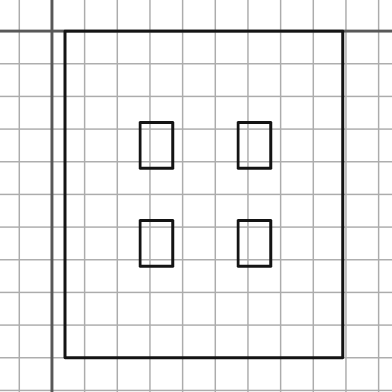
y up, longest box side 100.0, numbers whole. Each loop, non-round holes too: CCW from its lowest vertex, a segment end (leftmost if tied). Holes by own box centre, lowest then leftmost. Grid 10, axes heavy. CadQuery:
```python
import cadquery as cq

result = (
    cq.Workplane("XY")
    .moveTo(4.0, -100.0)
    .lineTo(89.0, -100.0)
    .lineTo(89.0, 0.0)
    .lineTo(4.0, 0.0)
    .close()
    .moveTo(27.0, -72.0)
    .lineTo(37.0, -72.0)
    .lineTo(37.0, -58.0)
    .lineTo(27.0, -58.0)
    .close()
    .moveTo(57.0, -72.0)
    .lineTo(67.0, -72.0)
    .lineTo(67.0, -58.0)
    .lineTo(57.0, -58.0)
    .close()
    .moveTo(27.0, -42.0)
    .lineTo(37.0, -42.0)
    .lineTo(37.0, -28.0)
    .lineTo(27.0, -28.0)
    .close()
    .moveTo(57.0, -42.0)
    .lineTo(67.0, -42.0)
    .lineTo(67.0, -28.0)
    .lineTo(57.0, -28.0)
    .close()
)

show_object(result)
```